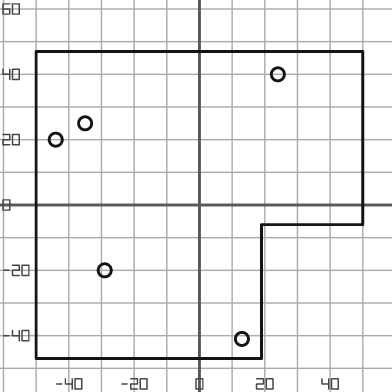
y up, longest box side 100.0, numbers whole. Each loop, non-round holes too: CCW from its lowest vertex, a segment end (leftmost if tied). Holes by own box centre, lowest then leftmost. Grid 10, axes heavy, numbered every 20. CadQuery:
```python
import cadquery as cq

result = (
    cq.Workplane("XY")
    .moveTo(-50.0, -47.0)
    .lineTo(19.0, -47.0)
    .lineTo(19.0, -6.0)
    .lineTo(50.0, -6.0)
    .lineTo(50.0, 47.0)
    .lineTo(-50.0, 47.0)
    .close()
    .moveTo(13.0, -41.0)
    .circle(2.0)
    .moveTo(-29.0, -20.0)
    .circle(2.0)
    .moveTo(-44.0, 20.0)
    .circle(2.0)
    .moveTo(-35.0, 25.0)
    .circle(2.0)
    .moveTo(24.0, 40.0)
    .circle(2.0)
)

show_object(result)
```